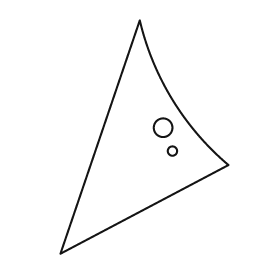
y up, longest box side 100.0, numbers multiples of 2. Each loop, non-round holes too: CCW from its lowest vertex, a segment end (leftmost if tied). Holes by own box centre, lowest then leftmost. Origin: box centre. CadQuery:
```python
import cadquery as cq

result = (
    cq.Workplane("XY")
    .moveTo(-36.0, -50.0)
    .lineTo(36.0, -12.0)
    .threePointArc((12.0, 16.0), (-2.0, 50.0))
    .close()
    .moveTo(12.0, -6.0)
    .circle(2.0)
    .moveTo(8.0, 4.0)
    .circle(4.0)
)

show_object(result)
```